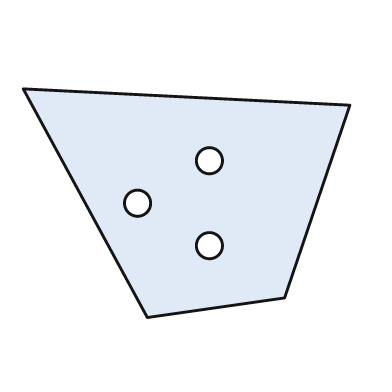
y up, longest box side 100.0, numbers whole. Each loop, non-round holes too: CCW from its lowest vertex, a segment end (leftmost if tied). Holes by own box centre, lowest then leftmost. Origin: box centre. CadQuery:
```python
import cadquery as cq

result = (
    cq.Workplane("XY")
    .moveTo(-12.0, -35.0)
    .lineTo(30.0, -29.0)
    .lineTo(50.0, 30.0)
    .lineTo(-50.0, 35.0)
    .close()
    .moveTo(7.0, -13.0)
    .circle(4.0)
    .moveTo(-15.0, 0.0)
    .circle(4.0)
    .moveTo(7.0, 13.0)
    .circle(4.0)
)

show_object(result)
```